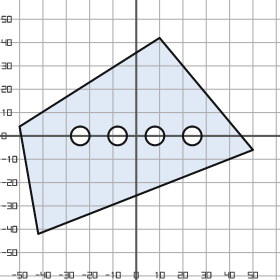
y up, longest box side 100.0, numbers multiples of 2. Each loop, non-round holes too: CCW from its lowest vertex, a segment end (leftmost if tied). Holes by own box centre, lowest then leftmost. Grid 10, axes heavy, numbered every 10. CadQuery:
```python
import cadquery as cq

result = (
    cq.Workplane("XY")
    .moveTo(-42.0, -42.0)
    .lineTo(50.0, -6.0)
    .lineTo(10.0, 42.0)
    .lineTo(-50.0, 4.0)
    .close()
    .moveTo(-24.0, 0.0)
    .circle(4.0)
    .moveTo(-8.0, 0.0)
    .circle(4.0)
    .moveTo(8.0, 0.0)
    .circle(4.0)
    .moveTo(24.0, 0.0)
    .circle(4.0)
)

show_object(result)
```